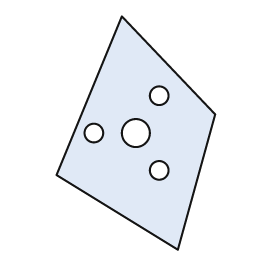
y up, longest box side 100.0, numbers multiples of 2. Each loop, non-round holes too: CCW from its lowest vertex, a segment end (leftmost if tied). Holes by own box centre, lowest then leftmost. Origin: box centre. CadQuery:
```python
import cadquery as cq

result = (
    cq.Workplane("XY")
    .moveTo(18.0, -50.0)
    .lineTo(34.0, 8.0)
    .lineTo(-6.0, 50.0)
    .lineTo(-34.0, -18.0)
    .close()
    .moveTo(10.0, -16.0)
    .circle(4.0)
    .moveTo(-18.0, 0.0)
    .circle(4.0)
    .moveTo(0.0, 0.0)
    .circle(6.0)
    .moveTo(10.0, 16.0)
    .circle(4.0)
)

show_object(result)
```